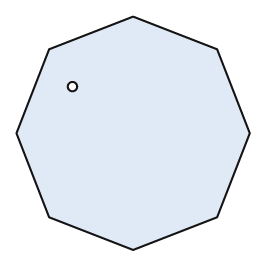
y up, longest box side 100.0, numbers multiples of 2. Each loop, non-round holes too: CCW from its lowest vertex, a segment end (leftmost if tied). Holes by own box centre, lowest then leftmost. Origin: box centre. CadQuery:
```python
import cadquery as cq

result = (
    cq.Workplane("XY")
    .moveTo(0.0, -50.0)
    .lineTo(36.0, -36.0)
    .lineTo(50.0, 0.0)
    .lineTo(36.0, 36.0)
    .lineTo(0.0, 50.0)
    .lineTo(-36.0, 36.0)
    .lineTo(-50.0, 0.0)
    .lineTo(-36.0, -36.0)
    .close()
    .moveTo(-26.0, 20.0)
    .circle(2.0)
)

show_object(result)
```